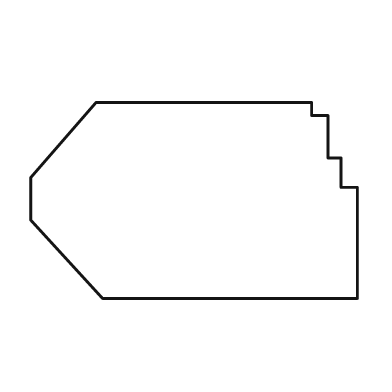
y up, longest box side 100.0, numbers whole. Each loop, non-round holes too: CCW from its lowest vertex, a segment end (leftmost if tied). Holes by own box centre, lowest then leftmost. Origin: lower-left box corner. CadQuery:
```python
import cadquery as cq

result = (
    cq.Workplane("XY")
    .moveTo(22.0, 0.0)
    .lineTo(100.0, 0.0)
    .lineTo(100.0, 34.0)
    .lineTo(95.0, 34.0)
    .lineTo(95.0, 43.0)
    .lineTo(91.0, 43.0)
    .lineTo(91.0, 56.0)
    .lineTo(86.0, 56.0)
    .lineTo(86.0, 60.0)
    .lineTo(20.0, 60.0)
    .lineTo(0.0, 37.0)
    .lineTo(0.0, 24.0)
    .close()
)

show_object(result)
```